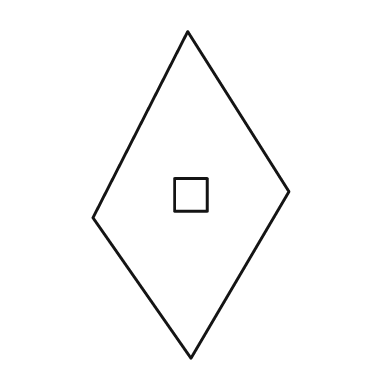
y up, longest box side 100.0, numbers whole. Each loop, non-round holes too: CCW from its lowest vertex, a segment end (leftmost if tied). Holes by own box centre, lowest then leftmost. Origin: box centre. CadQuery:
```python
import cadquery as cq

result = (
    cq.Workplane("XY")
    .moveTo(0.0, -50.0)
    .lineTo(30.0, 1.0)
    .lineTo(-1.0, 50.0)
    .lineTo(-30.0, -7.0)
    .close()
    .moveTo(-5.0, -5.0)
    .lineTo(5.0, -5.0)
    .lineTo(5.0, 5.0)
    .lineTo(-5.0, 5.0)
    .close()
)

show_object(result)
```